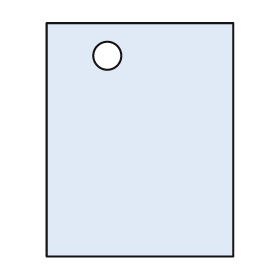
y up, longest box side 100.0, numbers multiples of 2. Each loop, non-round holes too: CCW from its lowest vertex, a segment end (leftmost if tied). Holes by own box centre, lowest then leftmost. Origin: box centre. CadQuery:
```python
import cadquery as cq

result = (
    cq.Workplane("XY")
    .moveTo(-40.0, -50.0)
    .lineTo(40.0, -50.0)
    .lineTo(40.0, 50.0)
    .lineTo(-40.0, 50.0)
    .close()
    .moveTo(-14.0, 36.0)
    .circle(6.0)
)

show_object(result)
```